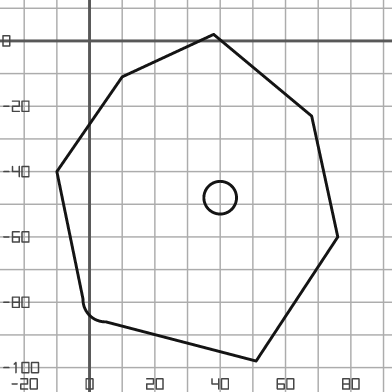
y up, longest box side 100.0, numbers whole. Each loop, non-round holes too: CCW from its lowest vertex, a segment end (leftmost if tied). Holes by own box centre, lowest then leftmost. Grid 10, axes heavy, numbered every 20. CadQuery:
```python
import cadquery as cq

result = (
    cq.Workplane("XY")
    .moveTo(51.0, -98.0)
    .lineTo(76.0, -60.0)
    .lineTo(68.0, -23.0)
    .lineTo(38.0, 2.0)
    .lineTo(10.0, -11.0)
    .lineTo(-10.0, -40.0)
    .lineTo(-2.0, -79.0)
    .threePointArc((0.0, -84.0), (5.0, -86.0))
    .close()
    .moveTo(40.0, -48.0)
    .circle(5.0)
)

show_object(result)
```